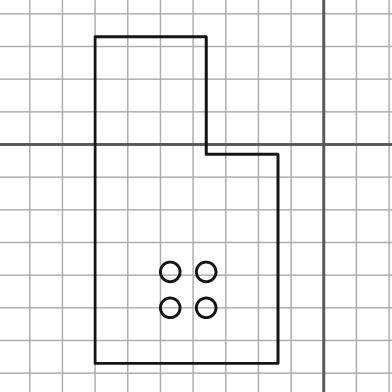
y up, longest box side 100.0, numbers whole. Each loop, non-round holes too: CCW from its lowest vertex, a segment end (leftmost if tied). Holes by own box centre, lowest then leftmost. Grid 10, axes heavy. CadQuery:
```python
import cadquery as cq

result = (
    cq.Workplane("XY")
    .moveTo(-70.0, -67.0)
    .lineTo(-14.0, -67.0)
    .lineTo(-14.0, -3.0)
    .lineTo(-36.0, -3.0)
    .lineTo(-36.0, 33.0)
    .lineTo(-70.0, 33.0)
    .close()
    .moveTo(-47.0, -50.0)
    .circle(3.0)
    .moveTo(-36.0, -50.0)
    .circle(3.0)
    .moveTo(-47.0, -39.0)
    .circle(3.0)
    .moveTo(-36.0, -39.0)
    .circle(3.0)
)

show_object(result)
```